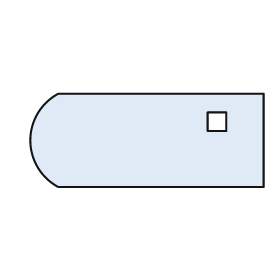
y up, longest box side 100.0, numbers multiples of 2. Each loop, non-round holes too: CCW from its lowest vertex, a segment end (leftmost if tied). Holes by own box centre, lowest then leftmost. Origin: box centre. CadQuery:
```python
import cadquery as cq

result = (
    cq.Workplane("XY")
    .moveTo(-38.0, -20.0)
    .lineTo(50.0, -20.0)
    .lineTo(50.0, 20.0)
    .lineTo(-38.0, 20.0)
    .threePointArc((-50.0, 0.0), (-38.0, -20.0))
    .close()
    .moveTo(26.0, 4.0)
    .lineTo(34.0, 4.0)
    .lineTo(34.0, 12.0)
    .lineTo(26.0, 12.0)
    .close()
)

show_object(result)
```